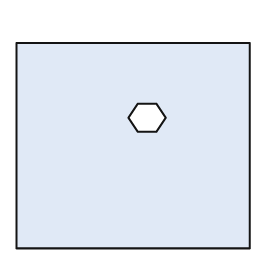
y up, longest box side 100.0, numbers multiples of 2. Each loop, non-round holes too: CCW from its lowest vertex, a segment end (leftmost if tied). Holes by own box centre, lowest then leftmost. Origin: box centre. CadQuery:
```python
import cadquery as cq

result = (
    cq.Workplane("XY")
    .moveTo(-50.0, -44.0)
    .lineTo(50.0, -44.0)
    .lineTo(50.0, 44.0)
    .lineTo(-50.0, 44.0)
    .close()
    .moveTo(2.0, 6.0)
    .lineTo(10.0, 6.0)
    .lineTo(14.0, 12.0)
    .lineTo(10.0, 18.0)
    .lineTo(2.0, 18.0)
    .lineTo(-2.0, 12.0)
    .close()
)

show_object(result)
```